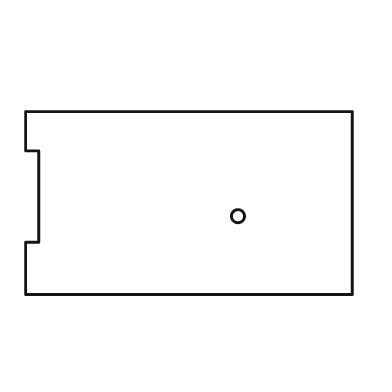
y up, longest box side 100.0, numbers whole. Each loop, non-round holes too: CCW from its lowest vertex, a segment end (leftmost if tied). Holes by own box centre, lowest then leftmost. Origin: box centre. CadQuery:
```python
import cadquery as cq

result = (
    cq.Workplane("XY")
    .moveTo(-50.0, -28.0)
    .lineTo(50.0, -28.0)
    .lineTo(50.0, 28.0)
    .lineTo(-50.0, 28.0)
    .lineTo(-50.0, 16.0)
    .lineTo(-46.0, 16.0)
    .lineTo(-46.0, -12.0)
    .lineTo(-50.0, -12.0)
    .close()
    .moveTo(15.0, -4.0)
    .circle(2.0)
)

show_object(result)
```